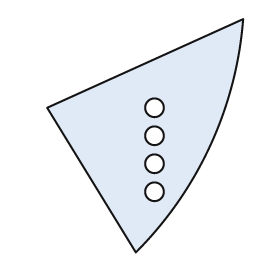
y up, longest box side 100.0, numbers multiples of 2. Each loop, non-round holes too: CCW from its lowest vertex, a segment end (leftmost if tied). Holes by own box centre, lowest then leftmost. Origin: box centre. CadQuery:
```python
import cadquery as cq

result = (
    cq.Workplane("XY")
    .moveTo(-4.0, -50.0)
    .threePointArc((28.0, -4.0), (42.0, 50.0))
    .lineTo(-42.0, 12.0)
    .close()
    .moveTo(4.0, -24.0)
    .circle(4.0)
    .moveTo(4.0, -12.0)
    .circle(4.0)
    .moveTo(4.0, 0.0)
    .circle(4.0)
    .moveTo(4.0, 12.0)
    .circle(4.0)
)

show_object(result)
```